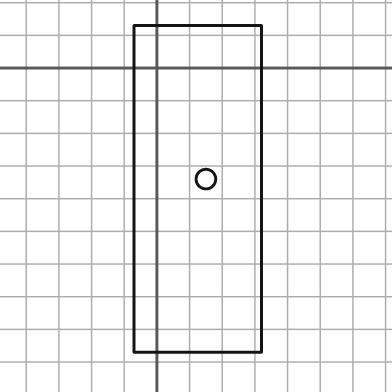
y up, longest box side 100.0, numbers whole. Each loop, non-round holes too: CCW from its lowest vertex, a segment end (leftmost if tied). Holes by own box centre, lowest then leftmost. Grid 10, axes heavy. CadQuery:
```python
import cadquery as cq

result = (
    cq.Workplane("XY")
    .moveTo(-7.0, -87.0)
    .lineTo(32.0, -87.0)
    .lineTo(32.0, 13.0)
    .lineTo(-7.0, 13.0)
    .close()
    .moveTo(15.0, -34.0)
    .circle(3.0)
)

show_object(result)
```